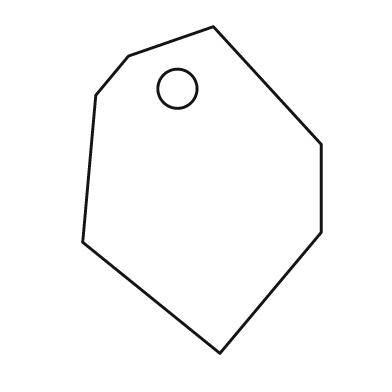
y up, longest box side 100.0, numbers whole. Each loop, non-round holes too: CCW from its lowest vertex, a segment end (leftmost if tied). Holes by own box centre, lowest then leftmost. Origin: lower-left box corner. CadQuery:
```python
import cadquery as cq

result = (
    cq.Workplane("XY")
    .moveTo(42.0, 0.0)
    .lineTo(73.0, 37.0)
    .lineTo(73.0, 64.0)
    .lineTo(40.0, 100.0)
    .lineTo(14.0, 91.0)
    .lineTo(4.0, 79.0)
    .lineTo(0.0, 34.0)
    .close()
    .moveTo(29.0, 81.0)
    .circle(6.0)
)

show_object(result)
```